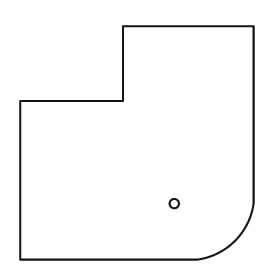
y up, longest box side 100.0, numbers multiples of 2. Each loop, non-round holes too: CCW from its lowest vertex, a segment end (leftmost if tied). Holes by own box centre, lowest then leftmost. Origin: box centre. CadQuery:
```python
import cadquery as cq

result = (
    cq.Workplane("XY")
    .moveTo(-50.0, -50.0)
    .lineTo(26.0, -50.0)
    .threePointArc((42.0, -42.0), (50.0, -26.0))
    .lineTo(50.0, 50.0)
    .lineTo(-6.0, 50.0)
    .lineTo(-6.0, 18.0)
    .lineTo(-50.0, 18.0)
    .close()
    .moveTo(16.0, -26.0)
    .circle(2.0)
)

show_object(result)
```